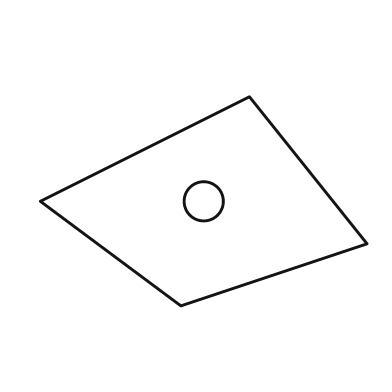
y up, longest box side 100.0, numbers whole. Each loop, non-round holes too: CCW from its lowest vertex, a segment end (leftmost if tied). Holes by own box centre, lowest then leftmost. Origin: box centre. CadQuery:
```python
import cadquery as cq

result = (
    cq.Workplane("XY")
    .moveTo(-7.0, -32.0)
    .lineTo(50.0, -13.0)
    .lineTo(14.0, 32.0)
    .lineTo(-50.0, 0.0)
    .close()
    .moveTo(0.0, 0.0)
    .circle(6.0)
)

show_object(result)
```